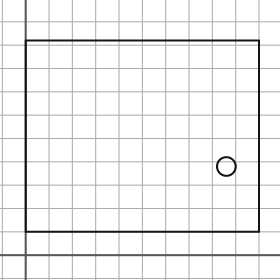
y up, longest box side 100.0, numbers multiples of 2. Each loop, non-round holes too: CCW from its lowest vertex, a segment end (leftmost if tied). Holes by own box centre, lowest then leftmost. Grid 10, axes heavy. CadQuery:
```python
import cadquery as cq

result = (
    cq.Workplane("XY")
    .moveTo(0.0, 10.0)
    .lineTo(100.0, 10.0)
    .lineTo(100.0, 92.0)
    .lineTo(0.0, 92.0)
    .close()
    .moveTo(86.0, 38.0)
    .circle(4.0)
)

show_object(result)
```